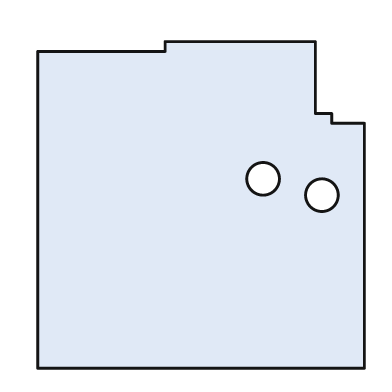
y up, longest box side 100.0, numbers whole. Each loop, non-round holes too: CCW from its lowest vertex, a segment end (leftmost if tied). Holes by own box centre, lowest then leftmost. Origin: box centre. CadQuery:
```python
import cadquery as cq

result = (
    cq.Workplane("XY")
    .moveTo(-50.0, -50.0)
    .lineTo(50.0, -50.0)
    .lineTo(50.0, 25.0)
    .lineTo(40.0, 25.0)
    .lineTo(40.0, 28.0)
    .lineTo(35.0, 28.0)
    .lineTo(35.0, 50.0)
    .lineTo(-11.0, 50.0)
    .lineTo(-11.0, 47.0)
    .lineTo(-50.0, 47.0)
    .close()
    .moveTo(37.0, 3.0)
    .circle(5.0)
    .moveTo(19.0, 8.0)
    .circle(5.0)
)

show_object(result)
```